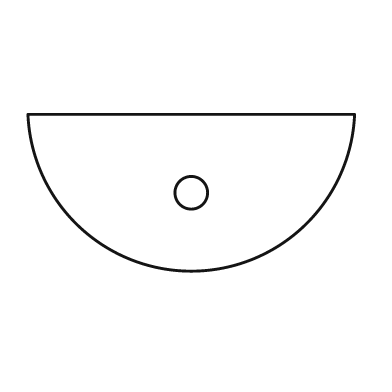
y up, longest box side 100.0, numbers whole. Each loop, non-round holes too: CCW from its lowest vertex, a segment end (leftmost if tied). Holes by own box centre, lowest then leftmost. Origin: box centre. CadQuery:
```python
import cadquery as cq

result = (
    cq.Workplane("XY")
    .moveTo(-50.0, 24.0)
    .threePointArc((0.0, -24.0), (50.0, 24.0))
    .close()
    .moveTo(0.0, 0.0)
    .circle(5.0)
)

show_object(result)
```